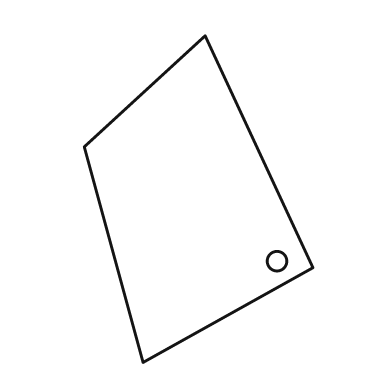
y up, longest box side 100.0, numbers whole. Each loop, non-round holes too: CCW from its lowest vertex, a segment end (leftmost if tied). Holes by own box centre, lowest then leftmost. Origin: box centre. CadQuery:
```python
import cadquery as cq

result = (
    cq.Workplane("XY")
    .moveTo(-17.0, -50.0)
    .lineTo(35.0, -21.0)
    .lineTo(2.0, 50.0)
    .lineTo(-35.0, 16.0)
    .close()
    .moveTo(24.0, -19.0)
    .circle(3.0)
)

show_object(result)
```